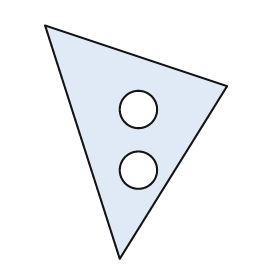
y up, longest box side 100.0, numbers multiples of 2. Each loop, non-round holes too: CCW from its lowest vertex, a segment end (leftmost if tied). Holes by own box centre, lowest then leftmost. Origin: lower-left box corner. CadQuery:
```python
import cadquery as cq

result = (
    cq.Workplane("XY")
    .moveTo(32.0, 0.0)
    .lineTo(78.0, 74.0)
    .lineTo(0.0, 100.0)
    .close()
    .moveTo(40.0, 38.0)
    .circle(8.0)
    .moveTo(40.0, 64.0)
    .circle(8.0)
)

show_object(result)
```